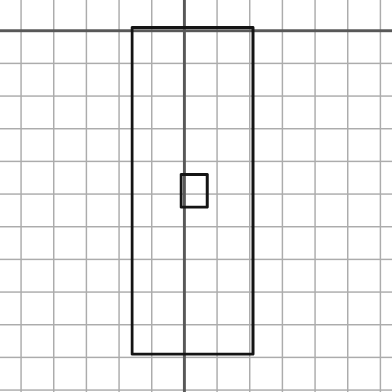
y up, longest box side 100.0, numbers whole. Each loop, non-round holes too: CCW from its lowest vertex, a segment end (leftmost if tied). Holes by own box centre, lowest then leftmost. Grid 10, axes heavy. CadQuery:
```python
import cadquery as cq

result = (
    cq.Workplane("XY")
    .moveTo(-16.0, -99.0)
    .lineTo(21.0, -99.0)
    .lineTo(21.0, 1.0)
    .lineTo(-16.0, 1.0)
    .close()
    .moveTo(-1.0, -54.0)
    .lineTo(7.0, -54.0)
    .lineTo(7.0, -44.0)
    .lineTo(-1.0, -44.0)
    .close()
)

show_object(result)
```